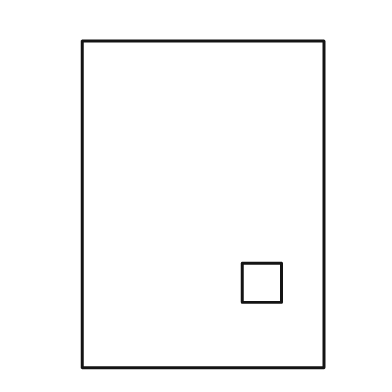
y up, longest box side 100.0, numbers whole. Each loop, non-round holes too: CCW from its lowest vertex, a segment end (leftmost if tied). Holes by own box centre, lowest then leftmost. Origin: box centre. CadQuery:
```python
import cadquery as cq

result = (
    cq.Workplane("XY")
    .moveTo(-37.0, -50.0)
    .lineTo(37.0, -50.0)
    .lineTo(37.0, 50.0)
    .lineTo(-37.0, 50.0)
    .close()
    .moveTo(12.0, -30.0)
    .lineTo(24.0, -30.0)
    .lineTo(24.0, -18.0)
    .lineTo(12.0, -18.0)
    .close()
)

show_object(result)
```